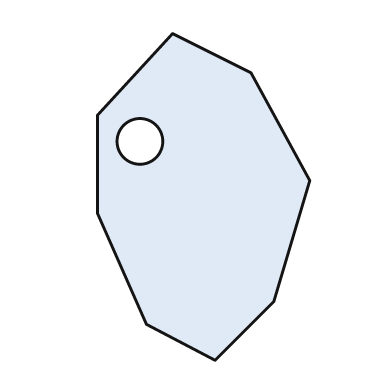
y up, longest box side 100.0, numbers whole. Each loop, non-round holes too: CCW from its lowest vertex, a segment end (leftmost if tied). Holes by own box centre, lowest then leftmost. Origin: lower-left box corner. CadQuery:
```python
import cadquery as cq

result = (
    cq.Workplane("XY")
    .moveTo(36.0, 0.0)
    .lineTo(54.0, 18.0)
    .lineTo(65.0, 55.0)
    .lineTo(47.0, 88.0)
    .lineTo(23.0, 100.0)
    .lineTo(0.0, 75.0)
    .lineTo(0.0, 45.0)
    .lineTo(15.0, 11.0)
    .close()
    .moveTo(13.0, 67.0)
    .circle(7.0)
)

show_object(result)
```